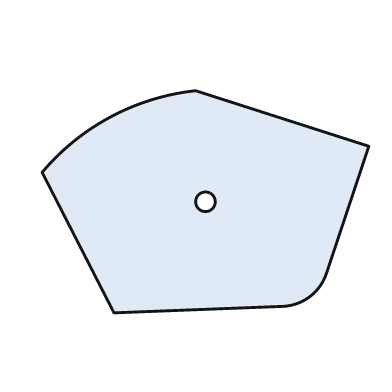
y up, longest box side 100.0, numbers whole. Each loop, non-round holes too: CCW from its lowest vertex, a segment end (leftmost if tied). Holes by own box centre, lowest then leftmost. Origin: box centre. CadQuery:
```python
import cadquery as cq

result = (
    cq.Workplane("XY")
    .moveTo(-28.0, -34.0)
    .lineTo(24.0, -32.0)
    .threePointArc((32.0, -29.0), (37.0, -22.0))
    .lineTo(50.0, 17.0)
    .lineTo(-3.0, 34.0)
    .threePointArc((-29.0, 26.0), (-50.0, 9.0))
    .close()
    .moveTo(0.0, 0.0)
    .circle(3.0)
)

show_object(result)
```